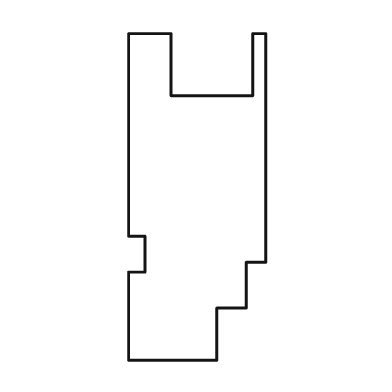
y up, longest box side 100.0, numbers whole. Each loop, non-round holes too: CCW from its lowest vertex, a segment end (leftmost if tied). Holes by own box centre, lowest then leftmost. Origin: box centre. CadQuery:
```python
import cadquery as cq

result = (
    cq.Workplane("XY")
    .moveTo(-21.0, -50.0)
    .lineTo(6.0, -50.0)
    .lineTo(6.0, -34.0)
    .lineTo(15.0, -34.0)
    .lineTo(15.0, -20.0)
    .lineTo(21.0, -20.0)
    .lineTo(21.0, 50.0)
    .lineTo(17.0, 50.0)
    .lineTo(17.0, 31.0)
    .lineTo(-8.0, 31.0)
    .lineTo(-8.0, 50.0)
    .lineTo(-21.0, 50.0)
    .lineTo(-21.0, -12.0)
    .lineTo(-16.0, -12.0)
    .lineTo(-16.0, -23.0)
    .lineTo(-21.0, -23.0)
    .close()
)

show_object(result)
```